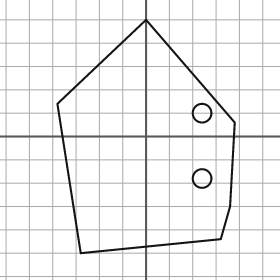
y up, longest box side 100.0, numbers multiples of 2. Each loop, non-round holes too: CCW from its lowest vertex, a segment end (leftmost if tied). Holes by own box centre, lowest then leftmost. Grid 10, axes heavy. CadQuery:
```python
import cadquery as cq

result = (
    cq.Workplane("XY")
    .moveTo(-28.0, -50.0)
    .lineTo(32.0, -44.0)
    .lineTo(36.0, -30.0)
    .lineTo(38.0, 6.0)
    .lineTo(0.0, 50.0)
    .lineTo(-38.0, 14.0)
    .close()
    .moveTo(24.0, -18.0)
    .circle(4.0)
    .moveTo(24.0, 10.0)
    .circle(4.0)
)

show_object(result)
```